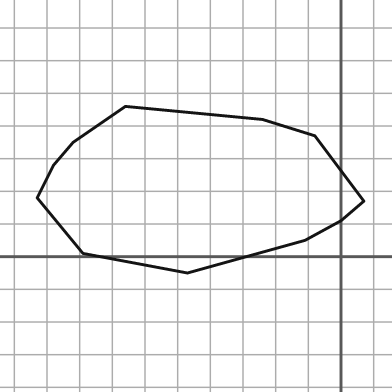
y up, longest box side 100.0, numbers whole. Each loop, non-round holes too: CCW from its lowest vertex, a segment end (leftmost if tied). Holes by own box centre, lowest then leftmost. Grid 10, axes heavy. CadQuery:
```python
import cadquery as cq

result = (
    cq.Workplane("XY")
    .moveTo(-47.0, -5.0)
    .lineTo(-11.0, 5.0)
    .lineTo(0.0, 11.0)
    .lineTo(7.0, 17.0)
    .lineTo(-8.0, 37.0)
    .lineTo(-24.0, 42.0)
    .lineTo(-66.0, 46.0)
    .lineTo(-82.0, 35.0)
    .lineTo(-88.0, 28.0)
    .lineTo(-93.0, 18.0)
    .lineTo(-79.0, 1.0)
    .close()
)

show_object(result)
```